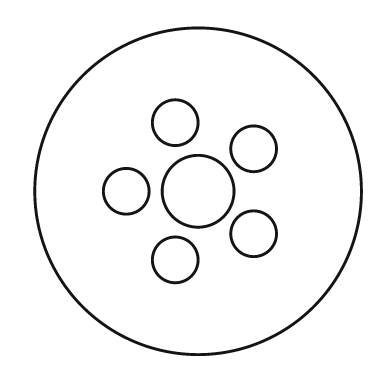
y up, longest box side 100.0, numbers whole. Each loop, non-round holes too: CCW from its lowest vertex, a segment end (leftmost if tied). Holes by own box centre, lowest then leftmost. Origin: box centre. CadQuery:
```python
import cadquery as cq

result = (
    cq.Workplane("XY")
    .moveTo(0.0, 0.0)
    .circle(50.0)
    .moveTo(-7.0, -21.0)
    .circle(7.0)
    .moveTo(17.0, -13.0)
    .circle(7.0)
    .moveTo(-22.0, 0.0)
    .circle(7.0)
    .moveTo(0.0, 0.0)
    .circle(11.0)
    .moveTo(17.0, 13.0)
    .circle(7.0)
    .moveTo(-7.0, 21.0)
    .circle(7.0)
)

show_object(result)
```